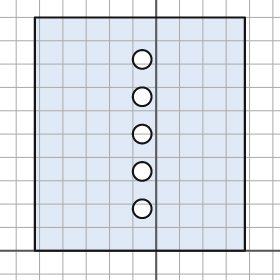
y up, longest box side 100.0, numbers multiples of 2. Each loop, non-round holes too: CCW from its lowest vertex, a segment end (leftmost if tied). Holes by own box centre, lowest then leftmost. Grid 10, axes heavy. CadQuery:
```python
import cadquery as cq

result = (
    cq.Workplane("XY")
    .moveTo(-52.0, 0.0)
    .lineTo(38.0, 0.0)
    .lineTo(38.0, 100.0)
    .lineTo(-52.0, 100.0)
    .close()
    .moveTo(-6.0, 18.0)
    .circle(4.0)
    .moveTo(-6.0, 34.0)
    .circle(4.0)
    .moveTo(-6.0, 50.0)
    .circle(4.0)
    .moveTo(-6.0, 66.0)
    .circle(4.0)
    .moveTo(-6.0, 82.0)
    .circle(4.0)
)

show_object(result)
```